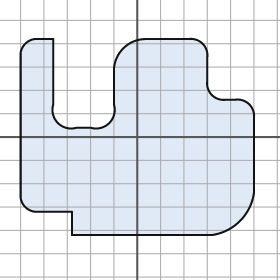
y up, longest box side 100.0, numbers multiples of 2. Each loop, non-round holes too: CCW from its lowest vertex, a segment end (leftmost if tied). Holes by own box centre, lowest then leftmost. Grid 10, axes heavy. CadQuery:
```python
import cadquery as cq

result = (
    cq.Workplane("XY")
    .moveTo(-28.0, -42.0)
    .lineTo(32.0, -42.0)
    .threePointArc((44.0, -36.0), (50.0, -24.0))
    .lineTo(50.0, 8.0)
    .threePointArc((48.0, 14.0), (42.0, 16.0))
    .lineTo(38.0, 16.0)
    .threePointArc((32.0, 18.0), (30.0, 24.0))
    .lineTo(30.0, 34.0)
    .threePointArc((28.0, 40.0), (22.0, 42.0))
    .lineTo(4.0, 42.0)
    .threePointArc((-6.0, 38.0), (-10.0, 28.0))
    .lineTo(-10.0, 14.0)
    .threePointArc((-12.0, 6.0), (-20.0, 4.0))
    .lineTo(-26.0, 4.0)
    .threePointArc((-34.0, 6.0), (-36.0, 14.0))
    .lineTo(-36.0, 42.0)
    .lineTo(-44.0, 42.0)
    .threePointArc((-48.0, 40.0), (-50.0, 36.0))
    .lineTo(-50.0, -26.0)
    .threePointArc((-48.0, -30.0), (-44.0, -32.0))
    .lineTo(-28.0, -32.0)
    .close()
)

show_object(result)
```